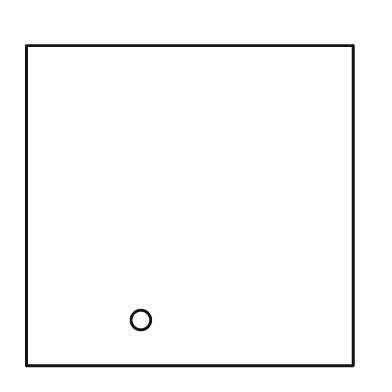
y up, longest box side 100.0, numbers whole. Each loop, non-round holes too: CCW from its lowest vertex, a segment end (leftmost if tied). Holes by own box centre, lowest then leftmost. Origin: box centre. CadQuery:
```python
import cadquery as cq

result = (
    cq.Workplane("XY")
    .moveTo(-50.0, -49.0)
    .lineTo(50.0, -49.0)
    .lineTo(50.0, 49.0)
    .lineTo(-50.0, 49.0)
    .close()
    .moveTo(-15.0, -35.0)
    .circle(3.0)
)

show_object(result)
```